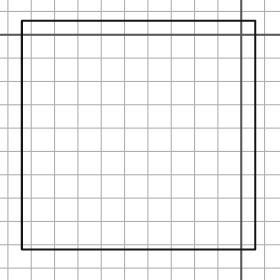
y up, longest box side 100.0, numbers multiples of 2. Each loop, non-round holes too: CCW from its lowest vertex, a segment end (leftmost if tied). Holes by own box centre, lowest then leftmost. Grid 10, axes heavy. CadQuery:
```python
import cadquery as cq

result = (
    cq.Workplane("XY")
    .moveTo(-94.0, -92.0)
    .lineTo(6.0, -92.0)
    .lineTo(6.0, 6.0)
    .lineTo(-94.0, 6.0)
    .close()
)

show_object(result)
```